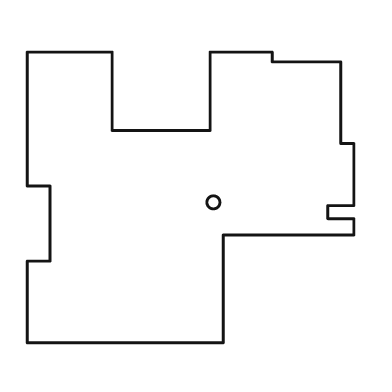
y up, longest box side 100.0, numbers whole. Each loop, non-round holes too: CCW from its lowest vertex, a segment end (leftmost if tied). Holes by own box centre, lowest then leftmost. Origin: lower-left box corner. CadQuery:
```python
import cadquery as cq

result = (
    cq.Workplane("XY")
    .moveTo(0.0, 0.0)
    .lineTo(60.0, 0.0)
    .lineTo(60.0, 33.0)
    .lineTo(100.0, 33.0)
    .lineTo(100.0, 38.0)
    .lineTo(92.0, 38.0)
    .lineTo(92.0, 42.0)
    .lineTo(100.0, 42.0)
    .lineTo(100.0, 61.0)
    .lineTo(96.0, 61.0)
    .lineTo(96.0, 86.0)
    .lineTo(75.0, 86.0)
    .lineTo(75.0, 89.0)
    .lineTo(56.0, 89.0)
    .lineTo(56.0, 65.0)
    .lineTo(26.0, 65.0)
    .lineTo(26.0, 89.0)
    .lineTo(0.0, 89.0)
    .lineTo(0.0, 48.0)
    .lineTo(7.0, 48.0)
    .lineTo(7.0, 25.0)
    .lineTo(0.0, 25.0)
    .close()
    .moveTo(57.0, 43.0)
    .circle(2.0)
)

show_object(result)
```